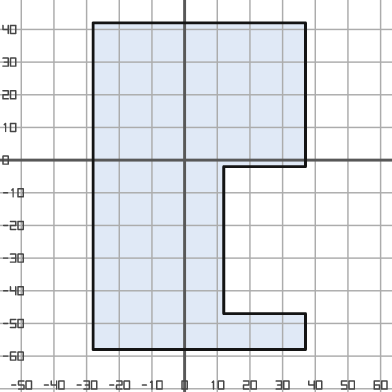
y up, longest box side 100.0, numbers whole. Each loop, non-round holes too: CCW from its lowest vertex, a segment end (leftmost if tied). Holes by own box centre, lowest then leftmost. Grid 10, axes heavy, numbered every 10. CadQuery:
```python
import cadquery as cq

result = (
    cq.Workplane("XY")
    .moveTo(-28.0, -58.0)
    .lineTo(37.0, -58.0)
    .lineTo(37.0, -47.0)
    .lineTo(12.0, -47.0)
    .lineTo(12.0, -2.0)
    .lineTo(37.0, -2.0)
    .lineTo(37.0, 42.0)
    .lineTo(-28.0, 42.0)
    .close()
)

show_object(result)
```